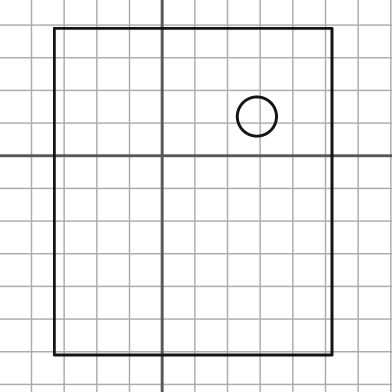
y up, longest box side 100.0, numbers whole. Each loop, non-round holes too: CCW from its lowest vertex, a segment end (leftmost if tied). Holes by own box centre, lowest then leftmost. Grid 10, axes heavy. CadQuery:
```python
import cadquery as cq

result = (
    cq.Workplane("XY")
    .moveTo(-33.0, -61.0)
    .lineTo(52.0, -61.0)
    .lineTo(52.0, 39.0)
    .lineTo(-33.0, 39.0)
    .close()
    .moveTo(29.0, 12.0)
    .circle(6.0)
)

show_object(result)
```